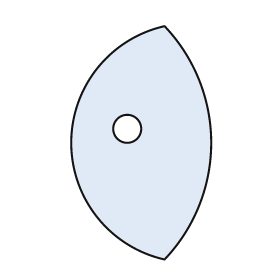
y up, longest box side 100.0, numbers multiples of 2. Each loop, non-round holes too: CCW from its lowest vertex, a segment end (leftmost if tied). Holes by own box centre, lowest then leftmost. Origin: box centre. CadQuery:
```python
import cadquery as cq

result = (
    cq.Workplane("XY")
    .moveTo(10.0, -50.0)
    .threePointArc((30.0, 0.0), (10.0, 50.0))
    .threePointArc((-30.0, 0.0), (10.0, -50.0))
    .close()
    .moveTo(-6.0, 6.0)
    .circle(6.0)
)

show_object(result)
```